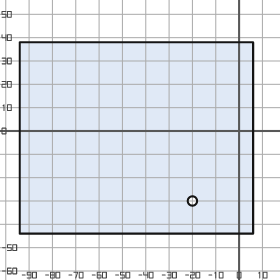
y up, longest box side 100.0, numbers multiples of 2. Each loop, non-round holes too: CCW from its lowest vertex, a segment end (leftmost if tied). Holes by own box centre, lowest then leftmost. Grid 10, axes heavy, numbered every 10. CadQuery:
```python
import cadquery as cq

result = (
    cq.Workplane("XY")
    .moveTo(-94.0, -44.0)
    .lineTo(6.0, -44.0)
    .lineTo(6.0, 38.0)
    .lineTo(-94.0, 38.0)
    .close()
    .moveTo(-20.0, -30.0)
    .circle(2.0)
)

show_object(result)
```